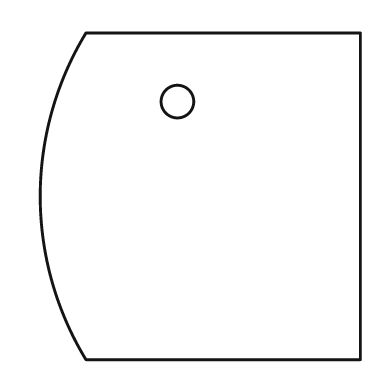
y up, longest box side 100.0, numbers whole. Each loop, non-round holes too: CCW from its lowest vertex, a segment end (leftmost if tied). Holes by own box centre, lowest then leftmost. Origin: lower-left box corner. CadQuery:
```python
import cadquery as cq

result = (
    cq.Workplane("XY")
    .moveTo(14.0, 0.0)
    .lineTo(98.0, 0.0)
    .lineTo(98.0, 100.0)
    .lineTo(14.0, 100.0)
    .threePointArc((0.0, 50.0), (14.0, 0.0))
    .close()
    .moveTo(42.0, 79.0)
    .circle(5.0)
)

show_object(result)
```